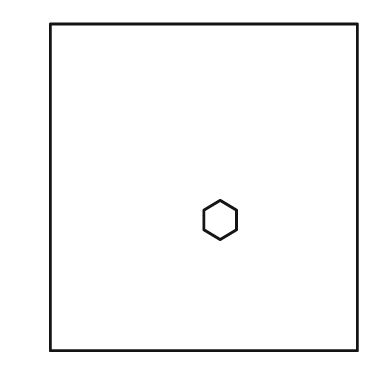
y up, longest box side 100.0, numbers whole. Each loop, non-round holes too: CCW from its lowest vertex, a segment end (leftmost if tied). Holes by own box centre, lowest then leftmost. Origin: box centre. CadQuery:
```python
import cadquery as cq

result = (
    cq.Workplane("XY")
    .moveTo(-47.0, -50.0)
    .lineTo(47.0, -50.0)
    .lineTo(47.0, 50.0)
    .lineTo(-47.0, 50.0)
    .close()
    .moveTo(5.0, -16.0)
    .lineTo(10.0, -13.0)
    .lineTo(10.0, -7.0)
    .lineTo(5.0, -4.0)
    .lineTo(0.0, -7.0)
    .lineTo(0.0, -13.0)
    .close()
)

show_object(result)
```